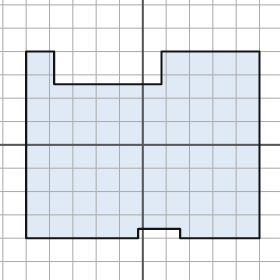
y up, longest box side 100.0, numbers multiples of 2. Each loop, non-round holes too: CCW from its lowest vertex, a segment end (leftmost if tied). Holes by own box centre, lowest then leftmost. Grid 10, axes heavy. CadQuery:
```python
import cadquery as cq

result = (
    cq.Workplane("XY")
    .moveTo(-50.0, -40.0)
    .lineTo(-2.0, -40.0)
    .lineTo(-2.0, -36.0)
    .lineTo(16.0, -36.0)
    .lineTo(16.0, -40.0)
    .lineTo(50.0, -40.0)
    .lineTo(50.0, 40.0)
    .lineTo(8.0, 40.0)
    .lineTo(8.0, 26.0)
    .lineTo(-38.0, 26.0)
    .lineTo(-38.0, 40.0)
    .lineTo(-50.0, 40.0)
    .close()
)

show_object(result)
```